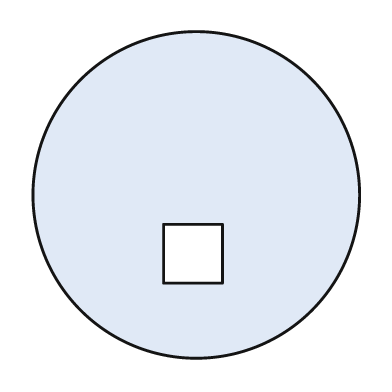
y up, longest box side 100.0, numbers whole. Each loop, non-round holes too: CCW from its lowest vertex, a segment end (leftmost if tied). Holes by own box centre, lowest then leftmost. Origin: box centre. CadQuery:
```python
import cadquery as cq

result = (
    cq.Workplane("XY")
    .moveTo(0.0, 0.0)
    .circle(50.0)
    .moveTo(-10.0, -27.0)
    .lineTo(8.0, -27.0)
    .lineTo(8.0, -9.0)
    .lineTo(-10.0, -9.0)
    .close()
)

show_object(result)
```